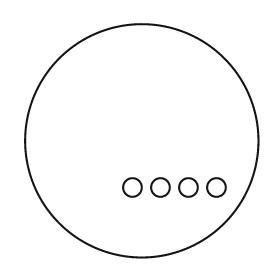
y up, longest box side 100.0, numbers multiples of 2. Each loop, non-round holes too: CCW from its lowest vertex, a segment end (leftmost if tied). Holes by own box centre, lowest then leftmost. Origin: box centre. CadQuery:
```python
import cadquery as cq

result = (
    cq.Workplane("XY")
    .moveTo(0.0, 0.0)
    .circle(50.0)
    .moveTo(-4.0, -20.0)
    .circle(4.0)
    .moveTo(8.0, -20.0)
    .circle(4.0)
    .moveTo(20.0, -20.0)
    .circle(4.0)
    .moveTo(32.0, -20.0)
    .circle(4.0)
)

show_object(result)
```